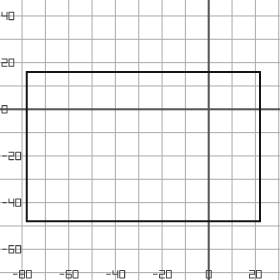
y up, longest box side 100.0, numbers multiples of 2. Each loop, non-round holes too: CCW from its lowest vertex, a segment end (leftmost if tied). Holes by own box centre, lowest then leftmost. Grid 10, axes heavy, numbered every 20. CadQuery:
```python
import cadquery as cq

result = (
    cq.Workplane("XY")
    .moveTo(-78.0, -48.0)
    .lineTo(22.0, -48.0)
    .lineTo(22.0, 16.0)
    .lineTo(-78.0, 16.0)
    .close()
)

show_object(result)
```